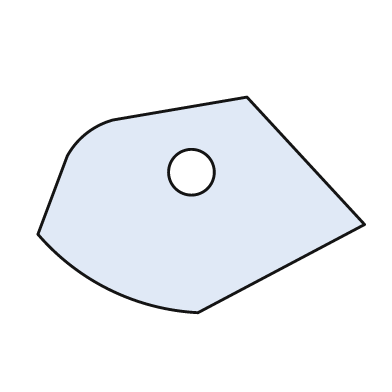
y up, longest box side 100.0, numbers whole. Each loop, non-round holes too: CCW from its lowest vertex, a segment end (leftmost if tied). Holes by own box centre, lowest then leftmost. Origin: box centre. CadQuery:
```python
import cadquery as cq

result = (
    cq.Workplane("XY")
    .moveTo(-1.0, -33.0)
    .lineTo(50.0, -6.0)
    .lineTo(14.0, 33.0)
    .lineTo(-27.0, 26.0)
    .threePointArc((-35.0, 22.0), (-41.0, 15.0))
    .lineTo(-50.0, -9.0)
    .threePointArc((-28.0, -26.0), (-1.0, -33.0))
    .close()
    .moveTo(-3.0, 10.0)
    .circle(7.0)
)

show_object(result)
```